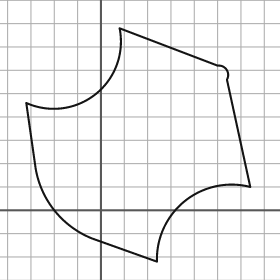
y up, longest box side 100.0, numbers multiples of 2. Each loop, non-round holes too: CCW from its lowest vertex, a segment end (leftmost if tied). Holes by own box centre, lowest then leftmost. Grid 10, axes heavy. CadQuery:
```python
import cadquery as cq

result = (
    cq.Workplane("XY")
    .moveTo(24.0, -22.0)
    .threePointArc((36.0, 4.0), (64.0, 10.0))
    .lineTo(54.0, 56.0)
    .threePointArc((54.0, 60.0), (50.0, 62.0))
    .lineTo(8.0, 78.0)
    .threePointArc((-2.0, 50.0), (-32.0, 46.0))
    .lineTo(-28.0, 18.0)
    .threePointArc((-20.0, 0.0), (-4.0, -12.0))
    .close()
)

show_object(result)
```